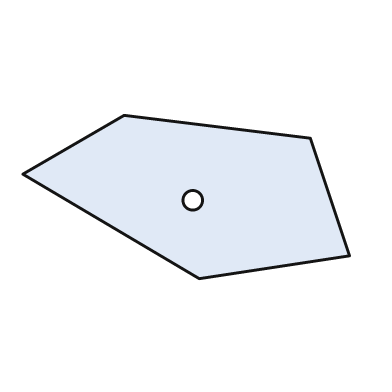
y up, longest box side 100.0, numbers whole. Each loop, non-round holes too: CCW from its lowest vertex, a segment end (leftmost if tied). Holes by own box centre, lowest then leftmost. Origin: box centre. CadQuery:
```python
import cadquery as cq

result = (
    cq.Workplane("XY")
    .moveTo(4.0, -25.0)
    .lineTo(50.0, -18.0)
    .lineTo(38.0, 18.0)
    .lineTo(-19.0, 25.0)
    .lineTo(-50.0, 7.0)
    .close()
    .moveTo(2.0, -1.0)
    .circle(3.0)
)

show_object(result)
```